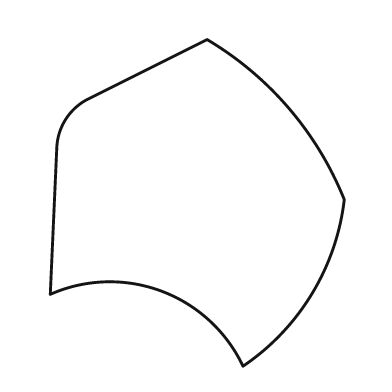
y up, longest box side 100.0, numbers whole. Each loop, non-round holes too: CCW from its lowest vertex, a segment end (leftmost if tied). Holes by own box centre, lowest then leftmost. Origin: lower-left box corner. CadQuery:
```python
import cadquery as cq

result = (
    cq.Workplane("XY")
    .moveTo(59.0, 0.0)
    .threePointArc((80.0, 22.0), (90.0, 51.0))
    .threePointArc((73.0, 79.0), (48.0, 100.0))
    .lineTo(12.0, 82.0)
    .threePointArc((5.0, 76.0), (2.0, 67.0))
    .lineTo(0.0, 22.0)
    .threePointArc((34.0, 23.0), (59.0, 0.0))
    .close()
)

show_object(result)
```